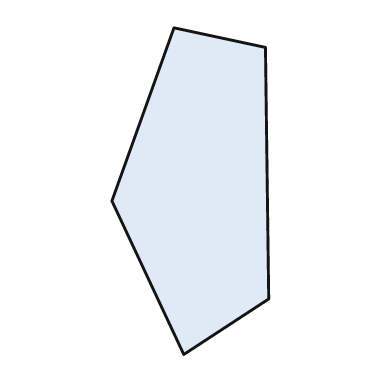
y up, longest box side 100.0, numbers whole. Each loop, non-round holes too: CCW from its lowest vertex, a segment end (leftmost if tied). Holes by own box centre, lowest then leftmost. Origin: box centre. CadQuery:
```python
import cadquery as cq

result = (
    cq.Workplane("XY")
    .moveTo(-2.0, -50.0)
    .lineTo(24.0, -33.0)
    .lineTo(23.0, 44.0)
    .lineTo(-5.0, 50.0)
    .lineTo(-24.0, -3.0)
    .close()
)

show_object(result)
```